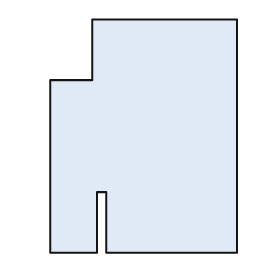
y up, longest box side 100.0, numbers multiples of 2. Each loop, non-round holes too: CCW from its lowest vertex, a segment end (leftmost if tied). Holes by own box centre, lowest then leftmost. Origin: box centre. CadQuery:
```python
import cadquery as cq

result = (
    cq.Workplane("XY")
    .moveTo(-40.0, -50.0)
    .lineTo(-20.0, -50.0)
    .lineTo(-20.0, -24.0)
    .lineTo(-16.0, -24.0)
    .lineTo(-16.0, -50.0)
    .lineTo(40.0, -50.0)
    .lineTo(40.0, 50.0)
    .lineTo(-22.0, 50.0)
    .lineTo(-22.0, 24.0)
    .lineTo(-40.0, 24.0)
    .close()
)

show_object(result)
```